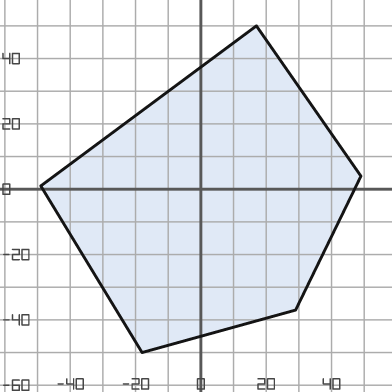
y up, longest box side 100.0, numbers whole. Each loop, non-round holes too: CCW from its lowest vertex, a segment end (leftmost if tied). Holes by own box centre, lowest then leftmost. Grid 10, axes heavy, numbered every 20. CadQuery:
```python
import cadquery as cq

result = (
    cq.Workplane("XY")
    .moveTo(-18.0, -50.0)
    .lineTo(29.0, -37.0)
    .lineTo(49.0, 4.0)
    .lineTo(17.0, 50.0)
    .lineTo(-49.0, 1.0)
    .close()
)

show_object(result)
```